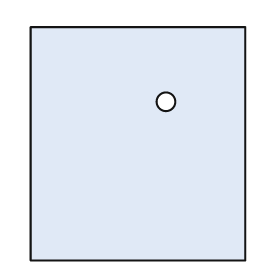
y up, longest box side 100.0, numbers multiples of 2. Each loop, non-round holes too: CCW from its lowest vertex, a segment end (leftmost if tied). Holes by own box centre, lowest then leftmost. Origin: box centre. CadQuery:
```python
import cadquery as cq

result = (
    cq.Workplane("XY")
    .moveTo(-46.0, -50.0)
    .lineTo(46.0, -50.0)
    .lineTo(46.0, 50.0)
    .lineTo(-46.0, 50.0)
    .close()
    .moveTo(12.0, 18.0)
    .circle(4.0)
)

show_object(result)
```